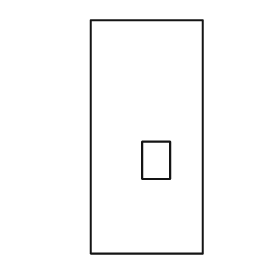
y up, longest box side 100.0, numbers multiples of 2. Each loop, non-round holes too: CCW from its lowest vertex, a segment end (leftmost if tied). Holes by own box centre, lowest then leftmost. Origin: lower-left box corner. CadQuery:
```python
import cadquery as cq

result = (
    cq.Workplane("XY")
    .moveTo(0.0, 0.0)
    .lineTo(48.0, 0.0)
    .lineTo(48.0, 100.0)
    .lineTo(0.0, 100.0)
    .close()
    .moveTo(22.0, 32.0)
    .lineTo(34.0, 32.0)
    .lineTo(34.0, 48.0)
    .lineTo(22.0, 48.0)
    .close()
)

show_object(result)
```